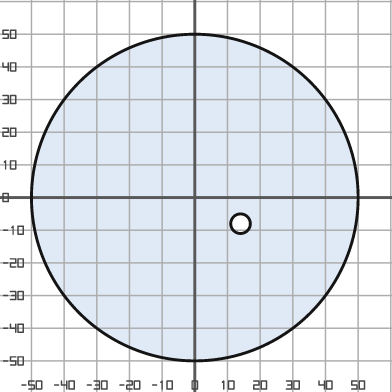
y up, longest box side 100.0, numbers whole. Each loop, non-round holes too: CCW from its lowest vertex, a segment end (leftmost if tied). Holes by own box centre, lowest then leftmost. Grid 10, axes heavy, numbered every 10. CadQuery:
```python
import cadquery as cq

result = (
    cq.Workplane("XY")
    .moveTo(0.0, 0.0)
    .circle(50.0)
    .moveTo(14.0, -8.0)
    .circle(3.0)
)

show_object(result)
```